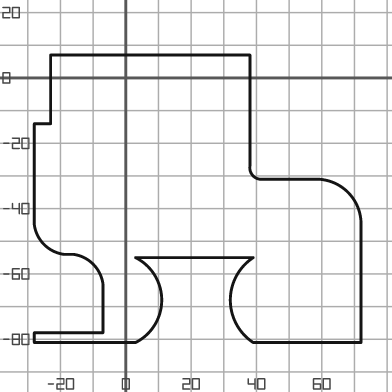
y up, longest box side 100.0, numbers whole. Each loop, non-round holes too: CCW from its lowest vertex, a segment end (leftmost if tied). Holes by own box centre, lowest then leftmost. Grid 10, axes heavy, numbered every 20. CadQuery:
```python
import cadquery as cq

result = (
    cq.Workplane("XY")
    .moveTo(-28.0, -81.0)
    .lineTo(3.0, -81.0)
    .threePointArc((11.0, -68.0), (3.0, -55.0))
    .lineTo(39.0, -55.0)
    .threePointArc((32.0, -68.0), (39.0, -81.0))
    .lineTo(72.0, -81.0)
    .lineTo(72.0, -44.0)
    .threePointArc((68.0, -35.0), (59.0, -31.0))
    .lineTo(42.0, -31.0)
    .threePointArc((39.0, -30.0), (38.0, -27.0))
    .lineTo(38.0, 7.0)
    .lineTo(-23.0, 7.0)
    .lineTo(-23.0, -14.0)
    .lineTo(-28.0, -14.0)
    .lineTo(-28.0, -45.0)
    .threePointArc((-25.0, -51.0), (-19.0, -54.0))
    .lineTo(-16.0, -54.0)
    .threePointArc((-10.0, -57.0), (-7.0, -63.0))
    .lineTo(-7.0, -78.0)
    .lineTo(-28.0, -78.0)
    .close()
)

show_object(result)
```